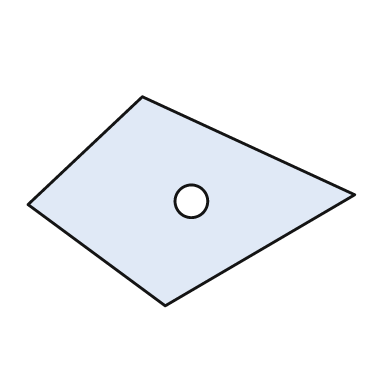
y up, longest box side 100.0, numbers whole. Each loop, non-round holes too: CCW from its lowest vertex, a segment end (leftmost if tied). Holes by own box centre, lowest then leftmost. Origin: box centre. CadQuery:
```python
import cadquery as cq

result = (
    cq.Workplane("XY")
    .moveTo(-8.0, -32.0)
    .lineTo(50.0, 2.0)
    .lineTo(-15.0, 32.0)
    .lineTo(-50.0, -1.0)
    .close()
    .moveTo(0.0, 0.0)
    .circle(5.0)
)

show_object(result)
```